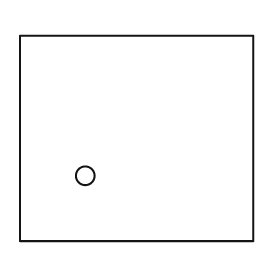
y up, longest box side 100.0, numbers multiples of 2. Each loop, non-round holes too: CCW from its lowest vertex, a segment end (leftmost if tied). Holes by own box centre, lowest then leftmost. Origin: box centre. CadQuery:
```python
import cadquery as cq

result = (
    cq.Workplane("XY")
    .moveTo(-50.0, -44.0)
    .lineTo(50.0, -44.0)
    .lineTo(50.0, 44.0)
    .lineTo(-50.0, 44.0)
    .close()
    .moveTo(-22.0, -16.0)
    .circle(4.0)
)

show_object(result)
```